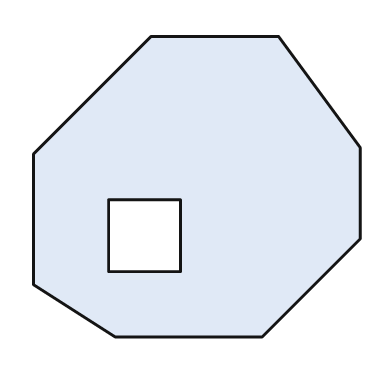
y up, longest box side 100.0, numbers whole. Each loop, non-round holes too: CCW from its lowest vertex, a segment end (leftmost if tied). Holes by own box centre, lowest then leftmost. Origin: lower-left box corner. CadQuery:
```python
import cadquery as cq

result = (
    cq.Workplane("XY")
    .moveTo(25.0, 0.0)
    .lineTo(70.0, 0.0)
    .lineTo(100.0, 30.0)
    .lineTo(100.0, 58.0)
    .lineTo(75.0, 92.0)
    .lineTo(36.0, 92.0)
    .lineTo(0.0, 56.0)
    .lineTo(0.0, 16.0)
    .close()
    .moveTo(23.0, 20.0)
    .lineTo(45.0, 20.0)
    .lineTo(45.0, 42.0)
    .lineTo(23.0, 42.0)
    .close()
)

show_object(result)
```